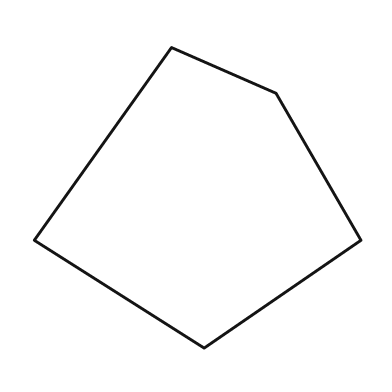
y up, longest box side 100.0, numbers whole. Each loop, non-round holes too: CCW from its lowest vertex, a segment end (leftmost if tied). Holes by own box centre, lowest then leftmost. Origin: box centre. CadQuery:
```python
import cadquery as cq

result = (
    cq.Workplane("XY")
    .moveTo(2.0, -46.0)
    .lineTo(50.0, -13.0)
    .lineTo(24.0, 32.0)
    .lineTo(-8.0, 46.0)
    .lineTo(-50.0, -13.0)
    .close()
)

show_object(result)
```